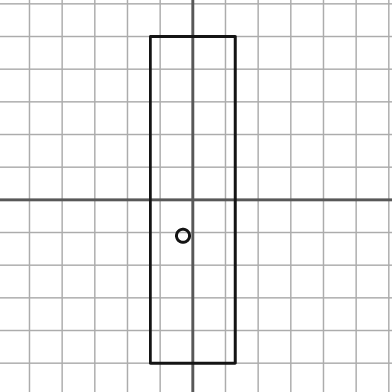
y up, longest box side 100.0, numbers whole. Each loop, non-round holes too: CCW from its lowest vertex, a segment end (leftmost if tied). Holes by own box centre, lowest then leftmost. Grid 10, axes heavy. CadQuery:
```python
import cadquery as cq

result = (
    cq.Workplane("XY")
    .moveTo(-13.0, -50.0)
    .lineTo(13.0, -50.0)
    .lineTo(13.0, 50.0)
    .lineTo(-13.0, 50.0)
    .close()
    .moveTo(-3.0, -11.0)
    .circle(2.0)
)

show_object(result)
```